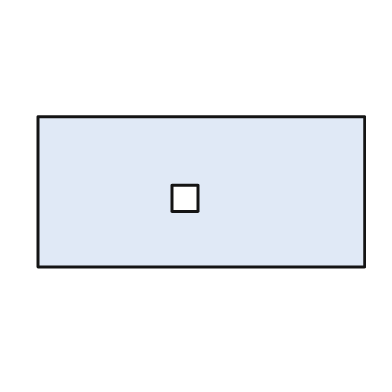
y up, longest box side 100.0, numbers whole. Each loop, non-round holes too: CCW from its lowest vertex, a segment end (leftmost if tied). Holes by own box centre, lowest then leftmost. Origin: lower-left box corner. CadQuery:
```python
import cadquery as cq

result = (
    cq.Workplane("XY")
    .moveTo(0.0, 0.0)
    .lineTo(100.0, 0.0)
    .lineTo(100.0, 46.0)
    .lineTo(0.0, 46.0)
    .close()
    .moveTo(41.0, 17.0)
    .lineTo(49.0, 17.0)
    .lineTo(49.0, 25.0)
    .lineTo(41.0, 25.0)
    .close()
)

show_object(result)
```